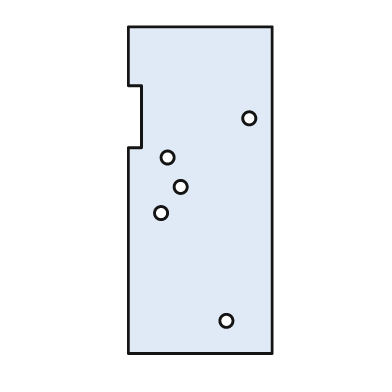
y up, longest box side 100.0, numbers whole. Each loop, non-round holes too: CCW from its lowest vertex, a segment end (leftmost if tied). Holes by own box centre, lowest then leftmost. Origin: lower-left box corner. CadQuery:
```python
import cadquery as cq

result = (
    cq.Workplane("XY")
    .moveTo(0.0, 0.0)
    .lineTo(44.0, 0.0)
    .lineTo(44.0, 100.0)
    .lineTo(0.0, 100.0)
    .lineTo(0.0, 82.0)
    .lineTo(4.0, 82.0)
    .lineTo(4.0, 63.0)
    .lineTo(0.0, 63.0)
    .close()
    .moveTo(30.0, 10.0)
    .circle(2.0)
    .moveTo(10.0, 43.0)
    .circle(2.0)
    .moveTo(16.0, 51.0)
    .circle(2.0)
    .moveTo(12.0, 60.0)
    .circle(2.0)
    .moveTo(37.0, 72.0)
    .circle(2.0)
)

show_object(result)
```